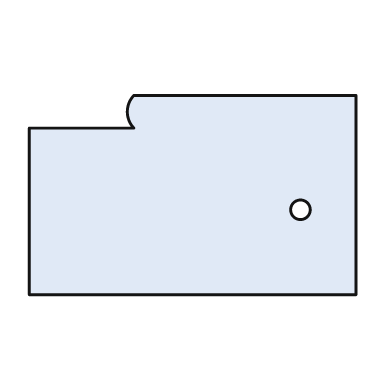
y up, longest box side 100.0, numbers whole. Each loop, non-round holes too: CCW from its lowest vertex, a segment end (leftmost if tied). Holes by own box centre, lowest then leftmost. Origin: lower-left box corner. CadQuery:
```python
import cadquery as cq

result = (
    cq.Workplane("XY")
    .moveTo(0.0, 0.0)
    .lineTo(100.0, 0.0)
    .lineTo(100.0, 61.0)
    .lineTo(32.0, 61.0)
    .threePointArc((30.0, 56.0), (32.0, 51.0))
    .lineTo(0.0, 51.0)
    .close()
    .moveTo(83.0, 26.0)
    .circle(3.0)
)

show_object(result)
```